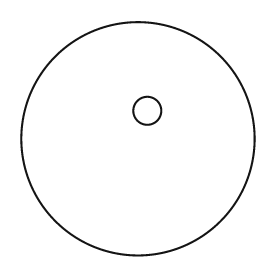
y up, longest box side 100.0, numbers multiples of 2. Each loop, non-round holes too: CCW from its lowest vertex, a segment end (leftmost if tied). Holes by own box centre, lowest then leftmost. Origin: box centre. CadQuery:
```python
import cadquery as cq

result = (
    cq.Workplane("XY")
    .moveTo(0.0, 0.0)
    .circle(50.0)
    .moveTo(4.0, 12.0)
    .circle(6.0)
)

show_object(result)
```